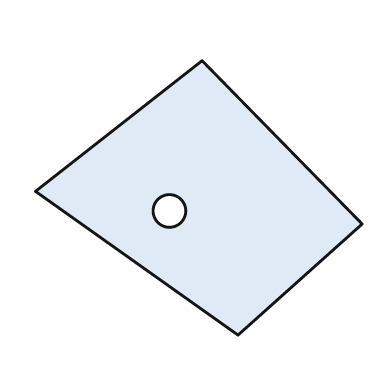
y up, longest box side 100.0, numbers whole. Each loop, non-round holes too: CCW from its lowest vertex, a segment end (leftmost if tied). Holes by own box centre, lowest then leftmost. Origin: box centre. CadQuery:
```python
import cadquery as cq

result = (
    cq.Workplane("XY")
    .moveTo(12.0, -42.0)
    .lineTo(50.0, -8.0)
    .lineTo(1.0, 42.0)
    .lineTo(-50.0, 2.0)
    .close()
    .moveTo(-9.0, -4.0)
    .circle(5.0)
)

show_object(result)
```